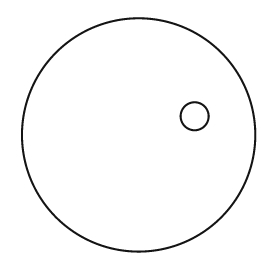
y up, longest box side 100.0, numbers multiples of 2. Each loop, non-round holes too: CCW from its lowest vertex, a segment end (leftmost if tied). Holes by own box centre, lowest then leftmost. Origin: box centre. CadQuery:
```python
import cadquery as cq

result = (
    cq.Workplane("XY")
    .moveTo(0.0, 0.0)
    .circle(50.0)
    .moveTo(24.0, 8.0)
    .circle(6.0)
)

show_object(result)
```